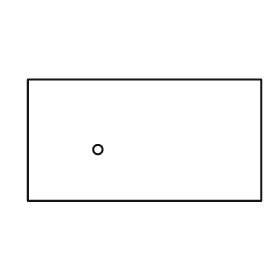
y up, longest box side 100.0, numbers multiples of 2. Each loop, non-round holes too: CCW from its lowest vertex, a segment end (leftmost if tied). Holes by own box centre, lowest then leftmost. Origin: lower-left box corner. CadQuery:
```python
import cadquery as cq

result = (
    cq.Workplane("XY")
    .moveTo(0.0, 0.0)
    .lineTo(100.0, 0.0)
    .lineTo(100.0, 52.0)
    .lineTo(0.0, 52.0)
    .close()
    .moveTo(30.0, 22.0)
    .circle(2.0)
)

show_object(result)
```